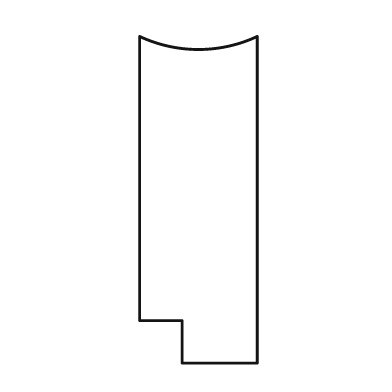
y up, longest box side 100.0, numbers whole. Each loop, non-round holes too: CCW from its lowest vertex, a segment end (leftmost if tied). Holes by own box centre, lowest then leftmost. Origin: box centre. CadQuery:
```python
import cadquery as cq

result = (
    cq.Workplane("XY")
    .moveTo(-5.0, -50.0)
    .lineTo(18.0, -50.0)
    .lineTo(18.0, 50.0)
    .threePointArc((0.0, 46.0), (-18.0, 50.0))
    .lineTo(-18.0, -37.0)
    .lineTo(-5.0, -37.0)
    .close()
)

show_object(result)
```